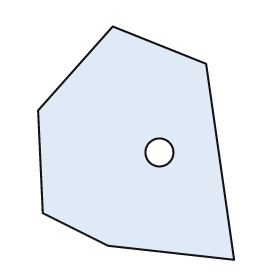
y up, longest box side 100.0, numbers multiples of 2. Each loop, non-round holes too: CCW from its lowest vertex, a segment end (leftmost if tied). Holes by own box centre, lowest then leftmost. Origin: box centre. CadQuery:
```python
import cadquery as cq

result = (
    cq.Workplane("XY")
    .moveTo(42.0, -50.0)
    .lineTo(30.0, 34.0)
    .lineTo(-10.0, 50.0)
    .lineTo(-42.0, 14.0)
    .lineTo(-40.0, -30.0)
    .lineTo(-12.0, -44.0)
    .close()
    .moveTo(10.0, -4.0)
    .circle(6.0)
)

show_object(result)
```